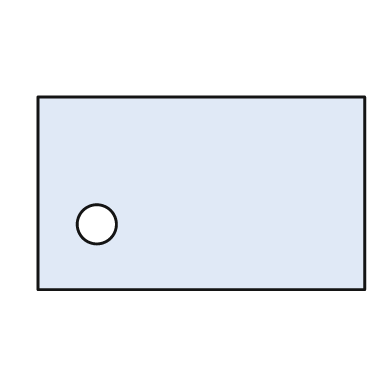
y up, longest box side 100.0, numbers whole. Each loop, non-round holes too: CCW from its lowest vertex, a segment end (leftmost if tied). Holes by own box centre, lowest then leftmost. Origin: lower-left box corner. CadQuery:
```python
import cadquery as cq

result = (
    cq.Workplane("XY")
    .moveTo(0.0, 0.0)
    .lineTo(100.0, 0.0)
    .lineTo(100.0, 59.0)
    .lineTo(0.0, 59.0)
    .close()
    .moveTo(18.0, 20.0)
    .circle(6.0)
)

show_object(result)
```